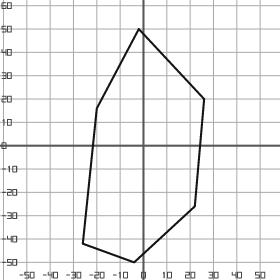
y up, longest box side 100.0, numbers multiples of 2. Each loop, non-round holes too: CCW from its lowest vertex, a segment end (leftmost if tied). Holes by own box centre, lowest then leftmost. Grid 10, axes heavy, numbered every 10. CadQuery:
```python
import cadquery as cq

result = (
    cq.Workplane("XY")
    .moveTo(-4.0, -50.0)
    .lineTo(22.0, -26.0)
    .lineTo(26.0, 20.0)
    .lineTo(-2.0, 50.0)
    .lineTo(-20.0, 16.0)
    .lineTo(-26.0, -42.0)
    .close()
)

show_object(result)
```